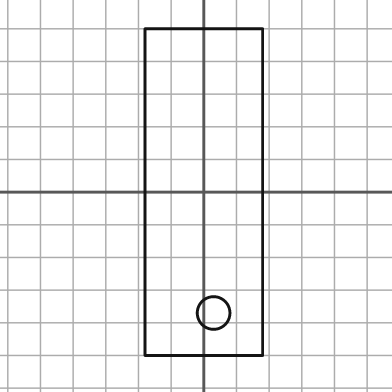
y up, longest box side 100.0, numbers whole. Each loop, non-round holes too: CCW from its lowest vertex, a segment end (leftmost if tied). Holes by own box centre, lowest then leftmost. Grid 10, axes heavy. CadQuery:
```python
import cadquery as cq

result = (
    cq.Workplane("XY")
    .moveTo(-18.0, -50.0)
    .lineTo(18.0, -50.0)
    .lineTo(18.0, 50.0)
    .lineTo(-18.0, 50.0)
    .close()
    .moveTo(3.0, -37.0)
    .circle(5.0)
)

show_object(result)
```